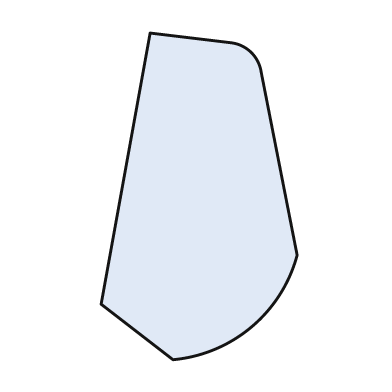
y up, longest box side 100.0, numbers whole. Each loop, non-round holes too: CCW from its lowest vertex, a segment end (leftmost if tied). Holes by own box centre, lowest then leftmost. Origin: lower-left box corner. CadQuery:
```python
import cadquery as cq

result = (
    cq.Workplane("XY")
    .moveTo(22.0, 0.0)
    .threePointArc((46.0, 10.0), (60.0, 32.0))
    .lineTo(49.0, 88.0)
    .threePointArc((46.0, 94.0), (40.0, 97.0))
    .lineTo(15.0, 100.0)
    .lineTo(0.0, 17.0)
    .close()
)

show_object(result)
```